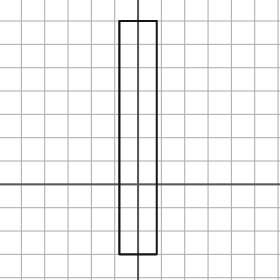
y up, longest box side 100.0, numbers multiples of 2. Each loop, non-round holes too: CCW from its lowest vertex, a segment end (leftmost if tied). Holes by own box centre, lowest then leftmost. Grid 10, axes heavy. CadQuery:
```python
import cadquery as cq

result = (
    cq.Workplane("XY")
    .moveTo(-8.0, -30.0)
    .lineTo(8.0, -30.0)
    .lineTo(8.0, 70.0)
    .lineTo(-8.0, 70.0)
    .close()
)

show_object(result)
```